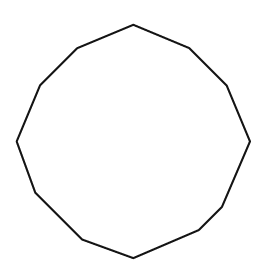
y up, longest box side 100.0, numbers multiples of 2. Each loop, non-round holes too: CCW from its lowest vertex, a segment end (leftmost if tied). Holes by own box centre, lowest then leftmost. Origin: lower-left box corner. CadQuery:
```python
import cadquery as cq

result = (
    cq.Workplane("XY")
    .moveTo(50.0, 0.0)
    .lineTo(78.0, 12.0)
    .lineTo(88.0, 22.0)
    .lineTo(100.0, 50.0)
    .lineTo(90.0, 74.0)
    .lineTo(74.0, 90.0)
    .lineTo(50.0, 100.0)
    .lineTo(26.0, 90.0)
    .lineTo(10.0, 74.0)
    .lineTo(0.0, 50.0)
    .lineTo(8.0, 28.0)
    .lineTo(28.0, 8.0)
    .close()
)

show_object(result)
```